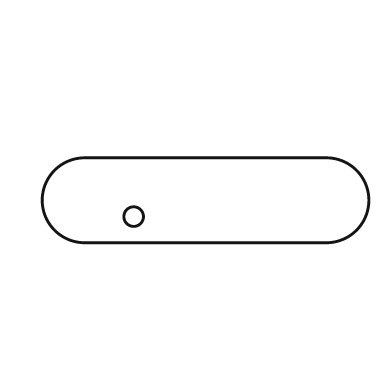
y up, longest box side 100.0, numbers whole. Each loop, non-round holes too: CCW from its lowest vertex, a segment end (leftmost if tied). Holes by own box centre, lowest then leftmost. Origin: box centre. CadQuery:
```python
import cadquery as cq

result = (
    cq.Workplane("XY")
    .moveTo(-37.0, -13.0)
    .lineTo(37.0, -13.0)
    .threePointArc((50.0, 0.0), (37.0, 13.0))
    .lineTo(-37.0, 13.0)
    .threePointArc((-50.0, 0.0), (-37.0, -13.0))
    .close()
    .moveTo(-22.0, -5.0)
    .circle(3.0)
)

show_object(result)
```